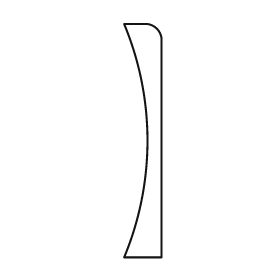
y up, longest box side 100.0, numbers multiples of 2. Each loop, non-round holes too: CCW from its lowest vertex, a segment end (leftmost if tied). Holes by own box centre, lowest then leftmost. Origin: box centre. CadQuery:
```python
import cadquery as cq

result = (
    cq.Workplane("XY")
    .moveTo(-8.0, -50.0)
    .lineTo(8.0, -50.0)
    .lineTo(8.0, 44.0)
    .threePointArc((6.0, 48.0), (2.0, 50.0))
    .lineTo(-8.0, 50.0)
    .threePointArc((2.0, 0.0), (-8.0, -50.0))
    .close()
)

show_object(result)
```